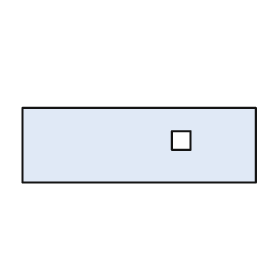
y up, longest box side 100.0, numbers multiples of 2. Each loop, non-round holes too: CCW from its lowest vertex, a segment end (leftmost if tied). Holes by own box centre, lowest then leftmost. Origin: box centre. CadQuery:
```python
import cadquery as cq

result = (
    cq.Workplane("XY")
    .moveTo(-50.0, -16.0)
    .lineTo(50.0, -16.0)
    .lineTo(50.0, 16.0)
    .lineTo(-50.0, 16.0)
    .close()
    .moveTo(14.0, -2.0)
    .lineTo(22.0, -2.0)
    .lineTo(22.0, 6.0)
    .lineTo(14.0, 6.0)
    .close()
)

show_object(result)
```